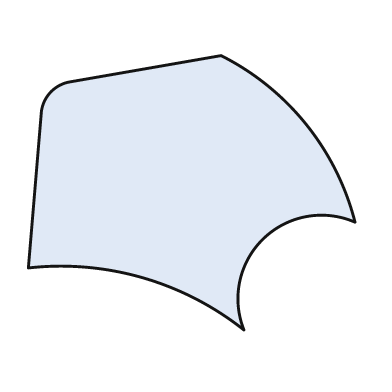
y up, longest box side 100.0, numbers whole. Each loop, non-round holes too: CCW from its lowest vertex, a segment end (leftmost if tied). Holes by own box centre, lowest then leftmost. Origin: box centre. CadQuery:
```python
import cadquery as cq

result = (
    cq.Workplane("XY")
    .moveTo(16.0, -42.0)
    .threePointArc((22.0, -14.0), (50.0, -9.0))
    .threePointArc((35.0, 21.0), (9.0, 42.0))
    .lineTo(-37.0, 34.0)
    .threePointArc((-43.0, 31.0), (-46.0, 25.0))
    .lineTo(-50.0, -23.0)
    .threePointArc((-15.0, -26.0), (16.0, -42.0))
    .close()
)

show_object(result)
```